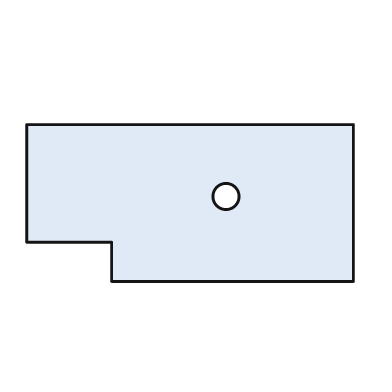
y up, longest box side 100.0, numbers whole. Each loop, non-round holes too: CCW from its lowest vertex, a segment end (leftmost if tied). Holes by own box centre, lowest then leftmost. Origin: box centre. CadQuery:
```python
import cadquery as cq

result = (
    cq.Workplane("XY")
    .moveTo(-24.0, -24.0)
    .lineTo(50.0, -24.0)
    .lineTo(50.0, 24.0)
    .lineTo(-50.0, 24.0)
    .lineTo(-50.0, -12.0)
    .lineTo(-24.0, -12.0)
    .close()
    .moveTo(11.0, 2.0)
    .circle(4.0)
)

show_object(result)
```